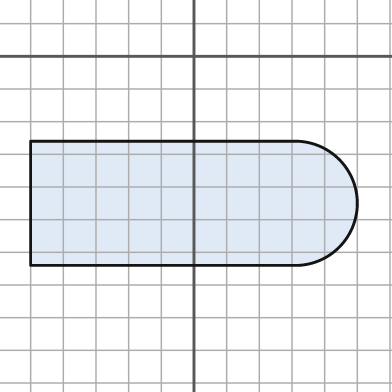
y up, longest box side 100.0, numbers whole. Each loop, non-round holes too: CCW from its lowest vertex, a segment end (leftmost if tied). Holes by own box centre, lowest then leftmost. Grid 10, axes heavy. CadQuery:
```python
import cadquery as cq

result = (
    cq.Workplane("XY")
    .moveTo(-50.0, -64.0)
    .lineTo(32.0, -64.0)
    .threePointArc((50.0, -45.0), (32.0, -26.0))
    .lineTo(-50.0, -26.0)
    .close()
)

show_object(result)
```